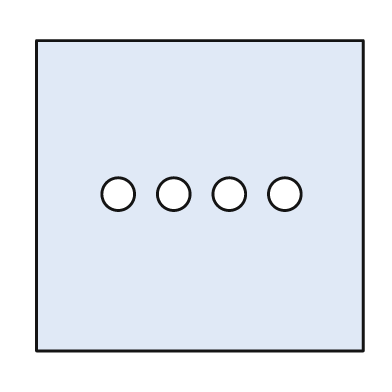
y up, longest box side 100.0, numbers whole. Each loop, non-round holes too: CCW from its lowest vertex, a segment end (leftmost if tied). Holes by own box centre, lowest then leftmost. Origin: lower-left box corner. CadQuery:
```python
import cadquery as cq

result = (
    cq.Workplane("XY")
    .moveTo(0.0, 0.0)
    .lineTo(100.0, 0.0)
    .lineTo(100.0, 95.0)
    .lineTo(0.0, 95.0)
    .close()
    .moveTo(25.0, 48.0)
    .circle(5.0)
    .moveTo(42.0, 48.0)
    .circle(5.0)
    .moveTo(59.0, 48.0)
    .circle(5.0)
    .moveTo(76.0, 48.0)
    .circle(5.0)
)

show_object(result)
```